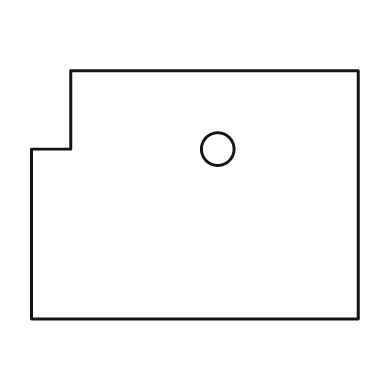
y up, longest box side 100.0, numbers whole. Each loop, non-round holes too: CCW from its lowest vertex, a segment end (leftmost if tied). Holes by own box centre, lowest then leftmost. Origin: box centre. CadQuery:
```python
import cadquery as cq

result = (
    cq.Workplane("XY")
    .moveTo(-50.0, -38.0)
    .lineTo(50.0, -38.0)
    .lineTo(50.0, 38.0)
    .lineTo(-38.0, 38.0)
    .lineTo(-38.0, 14.0)
    .lineTo(-50.0, 14.0)
    .close()
    .moveTo(7.0, 14.0)
    .circle(5.0)
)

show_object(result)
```